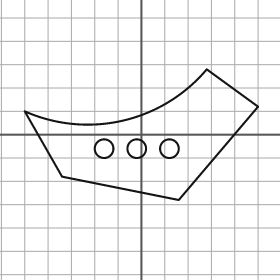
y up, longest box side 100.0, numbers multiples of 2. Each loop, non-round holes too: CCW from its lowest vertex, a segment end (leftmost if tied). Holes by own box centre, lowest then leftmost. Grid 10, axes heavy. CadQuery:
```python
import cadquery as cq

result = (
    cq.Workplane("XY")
    .moveTo(16.0, -28.0)
    .lineTo(50.0, 12.0)
    .lineTo(28.0, 28.0)
    .threePointArc((-8.0, 6.0), (-50.0, 10.0))
    .lineTo(-34.0, -18.0)
    .close()
    .moveTo(-16.0, -6.0)
    .circle(4.0)
    .moveTo(-2.0, -6.0)
    .circle(4.0)
    .moveTo(12.0, -6.0)
    .circle(4.0)
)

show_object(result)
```